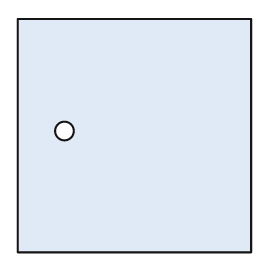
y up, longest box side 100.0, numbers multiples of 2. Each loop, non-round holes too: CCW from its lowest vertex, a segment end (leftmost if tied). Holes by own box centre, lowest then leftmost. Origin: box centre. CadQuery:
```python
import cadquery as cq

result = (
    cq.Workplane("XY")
    .moveTo(-50.0, -50.0)
    .lineTo(50.0, -50.0)
    .lineTo(50.0, 50.0)
    .lineTo(-50.0, 50.0)
    .close()
    .moveTo(-30.0, 2.0)
    .circle(4.0)
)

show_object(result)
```